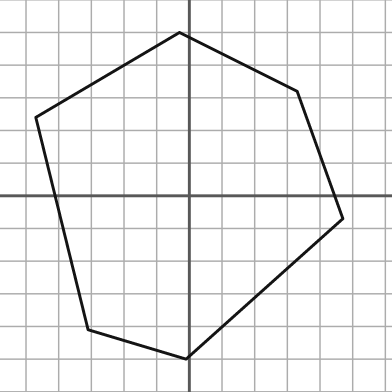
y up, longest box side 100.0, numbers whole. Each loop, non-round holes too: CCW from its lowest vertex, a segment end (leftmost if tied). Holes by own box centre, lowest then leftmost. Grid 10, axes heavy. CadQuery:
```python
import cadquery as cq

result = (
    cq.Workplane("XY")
    .moveTo(-1.0, -50.0)
    .lineTo(47.0, -7.0)
    .lineTo(33.0, 32.0)
    .lineTo(-3.0, 50.0)
    .lineTo(-47.0, 24.0)
    .lineTo(-31.0, -41.0)
    .close()
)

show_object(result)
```